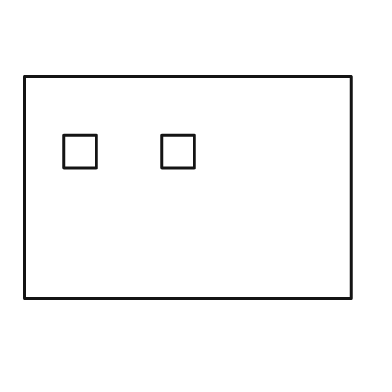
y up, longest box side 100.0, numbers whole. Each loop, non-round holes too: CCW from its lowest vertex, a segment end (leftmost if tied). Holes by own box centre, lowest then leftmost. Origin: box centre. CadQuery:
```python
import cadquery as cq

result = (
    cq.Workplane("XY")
    .moveTo(-50.0, -34.0)
    .lineTo(50.0, -34.0)
    .lineTo(50.0, 34.0)
    .lineTo(-50.0, 34.0)
    .close()
    .moveTo(-38.0, 6.0)
    .lineTo(-28.0, 6.0)
    .lineTo(-28.0, 16.0)
    .lineTo(-38.0, 16.0)
    .close()
    .moveTo(-8.0, 6.0)
    .lineTo(2.0, 6.0)
    .lineTo(2.0, 16.0)
    .lineTo(-8.0, 16.0)
    .close()
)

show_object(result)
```